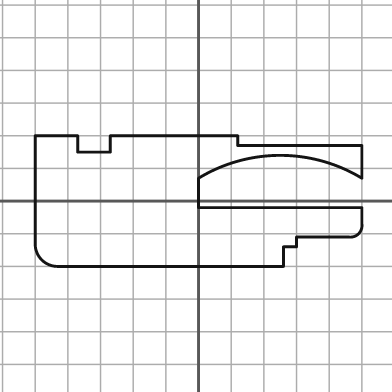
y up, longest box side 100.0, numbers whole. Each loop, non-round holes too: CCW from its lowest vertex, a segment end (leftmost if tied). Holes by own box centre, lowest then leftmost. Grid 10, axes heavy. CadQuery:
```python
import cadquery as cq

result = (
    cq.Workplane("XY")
    .moveTo(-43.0, -20.0)
    .lineTo(26.0, -20.0)
    .lineTo(26.0, -14.0)
    .lineTo(30.0, -14.0)
    .lineTo(30.0, -11.0)
    .lineTo(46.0, -11.0)
    .threePointArc((49.0, -10.0), (50.0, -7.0))
    .lineTo(50.0, -2.0)
    .lineTo(0.0, -2.0)
    .lineTo(0.0, 7.0)
    .threePointArc((25.0, 14.0), (50.0, 7.0))
    .lineTo(50.0, 17.0)
    .lineTo(12.0, 17.0)
    .lineTo(12.0, 20.0)
    .lineTo(-27.0, 20.0)
    .lineTo(-27.0, 15.0)
    .lineTo(-37.0, 15.0)
    .lineTo(-37.0, 20.0)
    .lineTo(-50.0, 20.0)
    .lineTo(-50.0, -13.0)
    .threePointArc((-48.0, -18.0), (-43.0, -20.0))
    .close()
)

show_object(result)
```